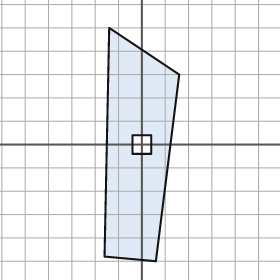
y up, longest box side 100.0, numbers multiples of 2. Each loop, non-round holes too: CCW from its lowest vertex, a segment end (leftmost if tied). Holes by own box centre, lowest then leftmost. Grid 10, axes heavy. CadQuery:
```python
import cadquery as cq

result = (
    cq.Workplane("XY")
    .moveTo(6.0, -50.0)
    .lineTo(16.0, 30.0)
    .lineTo(-14.0, 50.0)
    .lineTo(-16.0, -48.0)
    .close()
    .moveTo(-4.0, -4.0)
    .lineTo(4.0, -4.0)
    .lineTo(4.0, 4.0)
    .lineTo(-4.0, 4.0)
    .close()
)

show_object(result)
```